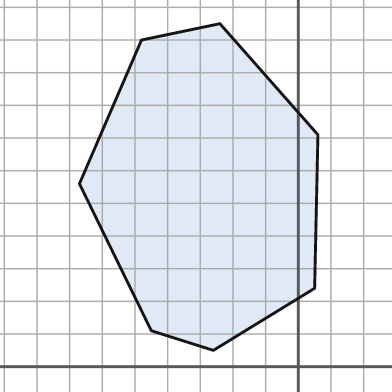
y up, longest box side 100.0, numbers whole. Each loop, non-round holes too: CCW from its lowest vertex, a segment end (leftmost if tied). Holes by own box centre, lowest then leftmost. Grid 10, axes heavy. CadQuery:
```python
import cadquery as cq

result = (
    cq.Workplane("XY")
    .moveTo(-26.0, 5.0)
    .lineTo(5.0, 24.0)
    .lineTo(6.0, 71.0)
    .lineTo(-24.0, 105.0)
    .lineTo(-48.0, 100.0)
    .lineTo(-67.0, 56.0)
    .lineTo(-45.0, 11.0)
    .close()
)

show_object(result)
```